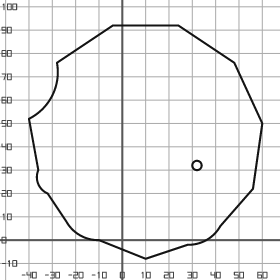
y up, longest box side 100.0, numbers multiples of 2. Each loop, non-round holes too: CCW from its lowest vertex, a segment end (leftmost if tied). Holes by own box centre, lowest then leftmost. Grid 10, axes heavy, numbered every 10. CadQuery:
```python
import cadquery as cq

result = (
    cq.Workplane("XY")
    .moveTo(10.0, -8.0)
    .lineTo(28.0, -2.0)
    .threePointArc((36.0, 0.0), (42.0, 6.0))
    .lineTo(56.0, 22.0)
    .lineTo(60.0, 50.0)
    .lineTo(48.0, 76.0)
    .lineTo(24.0, 92.0)
    .lineTo(-4.0, 92.0)
    .lineTo(-28.0, 76.0)
    .threePointArc((-30.0, 62.0), (-40.0, 52.0))
    .lineTo(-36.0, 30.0)
    .threePointArc((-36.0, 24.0), (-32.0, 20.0))
    .lineTo(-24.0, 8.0)
    .threePointArc((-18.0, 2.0), (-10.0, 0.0))
    .close()
    .moveTo(32.0, 32.0)
    .circle(2.0)
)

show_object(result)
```